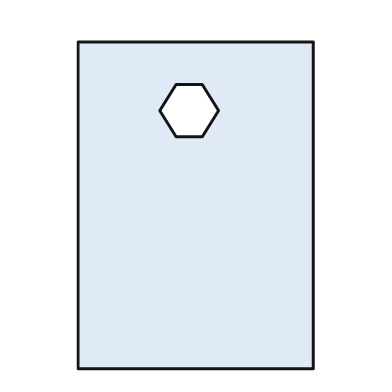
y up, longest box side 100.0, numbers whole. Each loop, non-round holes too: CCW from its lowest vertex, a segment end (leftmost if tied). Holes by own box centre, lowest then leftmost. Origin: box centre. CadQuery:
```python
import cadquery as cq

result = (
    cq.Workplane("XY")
    .moveTo(-36.0, -50.0)
    .lineTo(36.0, -50.0)
    .lineTo(36.0, 50.0)
    .lineTo(-36.0, 50.0)
    .close()
    .moveTo(-6.0, 21.0)
    .lineTo(2.0, 21.0)
    .lineTo(7.0, 29.0)
    .lineTo(2.0, 37.0)
    .lineTo(-6.0, 37.0)
    .lineTo(-11.0, 29.0)
    .close()
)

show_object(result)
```